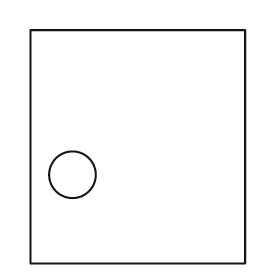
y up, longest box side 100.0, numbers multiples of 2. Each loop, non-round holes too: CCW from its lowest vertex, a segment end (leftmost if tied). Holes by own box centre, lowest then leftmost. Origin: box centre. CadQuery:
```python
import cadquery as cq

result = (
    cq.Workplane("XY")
    .moveTo(-46.0, -50.0)
    .lineTo(46.0, -50.0)
    .lineTo(46.0, 50.0)
    .lineTo(-46.0, 50.0)
    .close()
    .moveTo(-28.0, -12.0)
    .circle(10.0)
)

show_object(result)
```